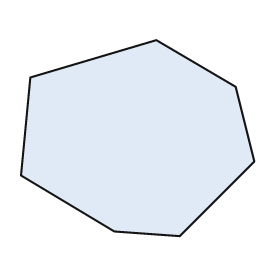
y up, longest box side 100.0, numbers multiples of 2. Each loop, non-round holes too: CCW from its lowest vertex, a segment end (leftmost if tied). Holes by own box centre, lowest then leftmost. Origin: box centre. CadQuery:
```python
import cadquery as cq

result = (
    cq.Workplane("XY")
    .moveTo(18.0, -42.0)
    .lineTo(50.0, -10.0)
    .lineTo(42.0, 22.0)
    .lineTo(8.0, 42.0)
    .lineTo(-46.0, 26.0)
    .lineTo(-50.0, -16.0)
    .lineTo(-10.0, -40.0)
    .close()
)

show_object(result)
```